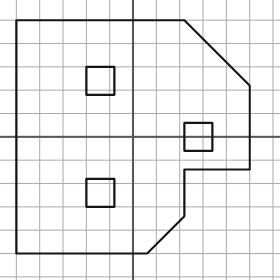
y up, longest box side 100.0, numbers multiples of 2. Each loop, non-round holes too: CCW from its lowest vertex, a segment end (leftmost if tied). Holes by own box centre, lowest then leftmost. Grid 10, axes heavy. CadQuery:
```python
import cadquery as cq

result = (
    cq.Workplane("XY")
    .moveTo(-50.0, -50.0)
    .lineTo(6.0, -50.0)
    .lineTo(22.0, -34.0)
    .lineTo(22.0, -14.0)
    .lineTo(50.0, -14.0)
    .lineTo(50.0, 22.0)
    .lineTo(22.0, 50.0)
    .lineTo(-50.0, 50.0)
    .close()
    .moveTo(-20.0, -30.0)
    .lineTo(-8.0, -30.0)
    .lineTo(-8.0, -18.0)
    .lineTo(-20.0, -18.0)
    .close()
    .moveTo(22.0, -6.0)
    .lineTo(34.0, -6.0)
    .lineTo(34.0, 6.0)
    .lineTo(22.0, 6.0)
    .close()
    .moveTo(-20.0, 18.0)
    .lineTo(-8.0, 18.0)
    .lineTo(-8.0, 30.0)
    .lineTo(-20.0, 30.0)
    .close()
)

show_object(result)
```